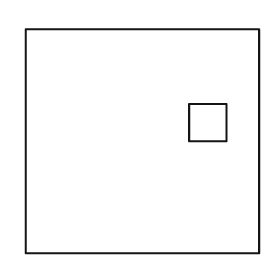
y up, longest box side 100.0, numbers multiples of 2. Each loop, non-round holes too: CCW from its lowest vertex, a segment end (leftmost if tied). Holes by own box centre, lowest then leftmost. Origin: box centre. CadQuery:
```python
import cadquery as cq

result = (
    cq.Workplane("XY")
    .moveTo(-50.0, -48.0)
    .lineTo(50.0, -48.0)
    .lineTo(50.0, 48.0)
    .lineTo(-50.0, 48.0)
    .close()
    .moveTo(20.0, 0.0)
    .lineTo(36.0, 0.0)
    .lineTo(36.0, 16.0)
    .lineTo(20.0, 16.0)
    .close()
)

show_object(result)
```